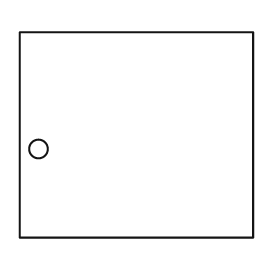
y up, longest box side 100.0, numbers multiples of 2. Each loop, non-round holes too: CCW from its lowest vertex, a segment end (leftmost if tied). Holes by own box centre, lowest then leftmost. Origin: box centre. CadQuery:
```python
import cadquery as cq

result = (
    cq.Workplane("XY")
    .moveTo(-50.0, -44.0)
    .lineTo(50.0, -44.0)
    .lineTo(50.0, 44.0)
    .lineTo(-50.0, 44.0)
    .close()
    .moveTo(-42.0, -6.0)
    .circle(4.0)
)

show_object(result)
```